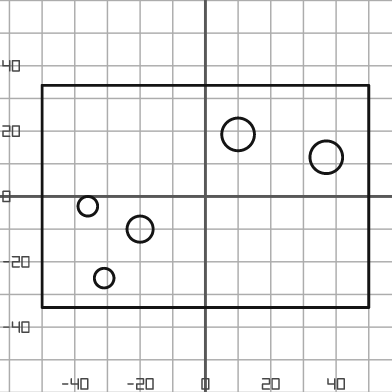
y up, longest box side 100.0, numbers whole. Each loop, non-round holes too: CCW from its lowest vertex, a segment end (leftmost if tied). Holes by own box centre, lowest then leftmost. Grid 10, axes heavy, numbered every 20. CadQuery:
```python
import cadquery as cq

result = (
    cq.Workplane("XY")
    .moveTo(-50.0, -34.0)
    .lineTo(50.0, -34.0)
    .lineTo(50.0, 34.0)
    .lineTo(-50.0, 34.0)
    .close()
    .moveTo(-31.0, -25.0)
    .circle(3.0)
    .moveTo(-20.0, -10.0)
    .circle(4.0)
    .moveTo(-36.0, -3.0)
    .circle(3.0)
    .moveTo(37.0, 12.0)
    .circle(5.0)
    .moveTo(10.0, 19.0)
    .circle(5.0)
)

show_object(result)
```